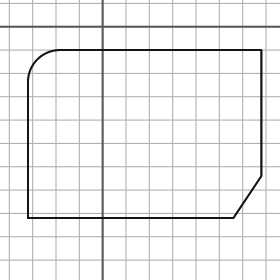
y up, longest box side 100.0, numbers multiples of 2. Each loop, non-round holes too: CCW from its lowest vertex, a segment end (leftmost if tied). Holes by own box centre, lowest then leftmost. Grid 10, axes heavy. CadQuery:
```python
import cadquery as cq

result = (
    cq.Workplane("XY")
    .moveTo(-32.0, -82.0)
    .lineTo(56.0, -82.0)
    .lineTo(68.0, -64.0)
    .lineTo(68.0, -10.0)
    .lineTo(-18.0, -10.0)
    .threePointArc((-28.0, -14.0), (-32.0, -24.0))
    .close()
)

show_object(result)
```